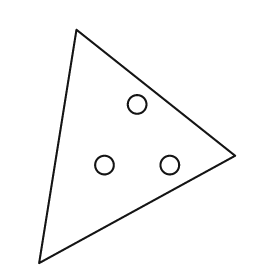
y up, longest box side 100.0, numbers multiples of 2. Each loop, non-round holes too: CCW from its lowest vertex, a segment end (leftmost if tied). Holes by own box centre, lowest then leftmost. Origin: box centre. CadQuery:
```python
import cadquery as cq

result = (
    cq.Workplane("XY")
    .moveTo(-42.0, -50.0)
    .lineTo(42.0, -4.0)
    .lineTo(-26.0, 50.0)
    .close()
    .moveTo(-14.0, -8.0)
    .circle(4.0)
    .moveTo(14.0, -8.0)
    .circle(4.0)
    .moveTo(0.0, 18.0)
    .circle(4.0)
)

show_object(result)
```